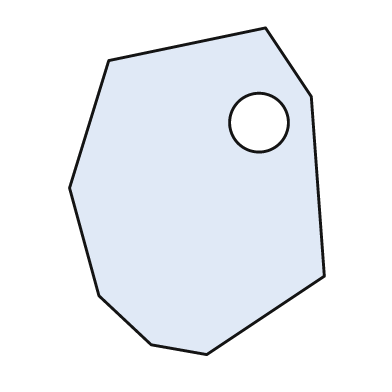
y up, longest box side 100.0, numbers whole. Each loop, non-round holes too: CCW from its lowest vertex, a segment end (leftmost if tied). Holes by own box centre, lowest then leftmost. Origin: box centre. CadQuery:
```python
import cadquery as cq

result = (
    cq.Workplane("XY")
    .moveTo(3.0, -50.0)
    .lineTo(39.0, -26.0)
    .lineTo(35.0, 29.0)
    .lineTo(21.0, 50.0)
    .lineTo(-27.0, 40.0)
    .lineTo(-39.0, 1.0)
    .lineTo(-30.0, -32.0)
    .lineTo(-14.0, -47.0)
    .close()
    .moveTo(19.0, 21.0)
    .circle(9.0)
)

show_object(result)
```